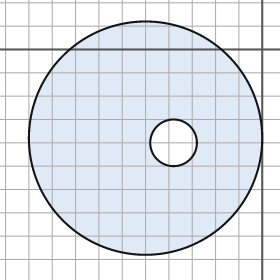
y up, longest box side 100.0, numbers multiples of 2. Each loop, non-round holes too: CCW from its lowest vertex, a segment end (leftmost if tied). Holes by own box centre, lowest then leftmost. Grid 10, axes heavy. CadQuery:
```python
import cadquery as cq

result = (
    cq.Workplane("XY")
    .moveTo(-50.0, -38.0)
    .circle(50.0)
    .moveTo(-38.0, -40.0)
    .circle(10.0)
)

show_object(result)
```